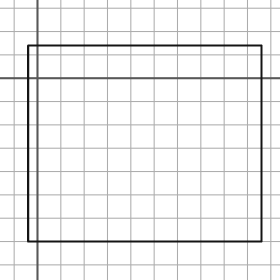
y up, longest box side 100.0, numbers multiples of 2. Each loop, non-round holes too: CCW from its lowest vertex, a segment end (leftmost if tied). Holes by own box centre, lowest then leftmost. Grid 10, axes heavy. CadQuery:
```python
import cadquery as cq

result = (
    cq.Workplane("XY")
    .moveTo(-4.0, -70.0)
    .lineTo(96.0, -70.0)
    .lineTo(96.0, 14.0)
    .lineTo(-4.0, 14.0)
    .close()
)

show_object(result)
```